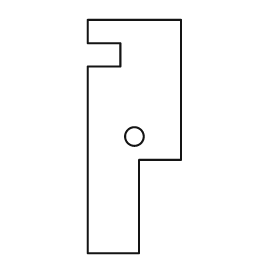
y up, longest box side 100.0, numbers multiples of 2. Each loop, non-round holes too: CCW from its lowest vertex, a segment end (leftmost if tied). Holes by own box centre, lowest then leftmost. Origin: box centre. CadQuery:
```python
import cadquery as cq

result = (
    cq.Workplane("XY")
    .moveTo(-20.0, -50.0)
    .lineTo(2.0, -50.0)
    .lineTo(2.0, -10.0)
    .lineTo(20.0, -10.0)
    .lineTo(20.0, 50.0)
    .lineTo(-20.0, 50.0)
    .lineTo(-20.0, 40.0)
    .lineTo(-6.0, 40.0)
    .lineTo(-6.0, 30.0)
    .lineTo(-20.0, 30.0)
    .close()
    .moveTo(0.0, 0.0)
    .circle(4.0)
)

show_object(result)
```